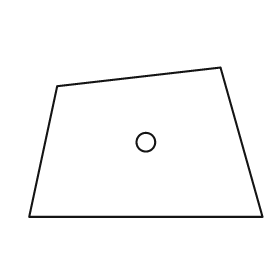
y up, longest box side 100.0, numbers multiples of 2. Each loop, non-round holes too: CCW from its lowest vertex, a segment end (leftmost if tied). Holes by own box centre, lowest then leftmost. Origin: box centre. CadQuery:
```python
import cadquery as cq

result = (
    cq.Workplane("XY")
    .moveTo(-50.0, -32.0)
    .lineTo(50.0, -32.0)
    .lineTo(32.0, 32.0)
    .lineTo(-38.0, 24.0)
    .close()
    .moveTo(0.0, 0.0)
    .circle(4.0)
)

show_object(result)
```